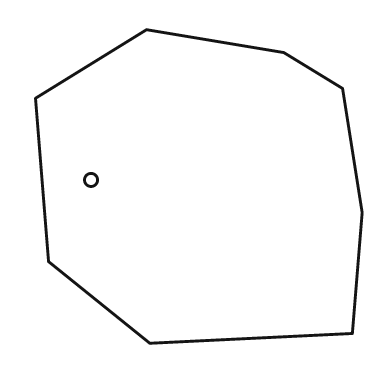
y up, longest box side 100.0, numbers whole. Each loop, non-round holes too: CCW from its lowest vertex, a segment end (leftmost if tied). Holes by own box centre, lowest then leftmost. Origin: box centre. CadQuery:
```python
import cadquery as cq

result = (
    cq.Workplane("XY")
    .moveTo(-15.0, -48.0)
    .lineTo(47.0, -45.0)
    .lineTo(50.0, -8.0)
    .lineTo(44.0, 30.0)
    .lineTo(26.0, 41.0)
    .lineTo(-16.0, 48.0)
    .lineTo(-50.0, 27.0)
    .lineTo(-46.0, -23.0)
    .close()
    .moveTo(-33.0, 2.0)
    .circle(2.0)
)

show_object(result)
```